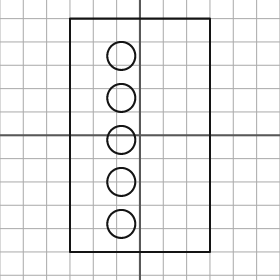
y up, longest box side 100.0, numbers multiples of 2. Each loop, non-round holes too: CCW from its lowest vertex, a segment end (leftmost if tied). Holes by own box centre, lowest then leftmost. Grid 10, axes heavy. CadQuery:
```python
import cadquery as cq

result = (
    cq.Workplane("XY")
    .moveTo(-30.0, -50.0)
    .lineTo(30.0, -50.0)
    .lineTo(30.0, 50.0)
    .lineTo(-30.0, 50.0)
    .close()
    .moveTo(-8.0, -38.0)
    .circle(6.0)
    .moveTo(-8.0, -20.0)
    .circle(6.0)
    .moveTo(-8.0, -2.0)
    .circle(6.0)
    .moveTo(-8.0, 16.0)
    .circle(6.0)
    .moveTo(-8.0, 34.0)
    .circle(6.0)
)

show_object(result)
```